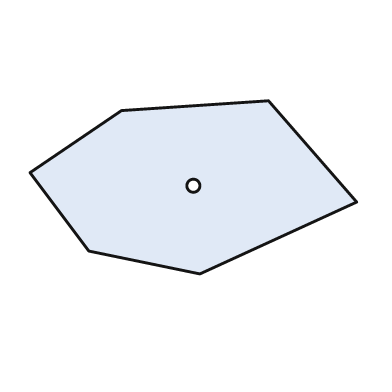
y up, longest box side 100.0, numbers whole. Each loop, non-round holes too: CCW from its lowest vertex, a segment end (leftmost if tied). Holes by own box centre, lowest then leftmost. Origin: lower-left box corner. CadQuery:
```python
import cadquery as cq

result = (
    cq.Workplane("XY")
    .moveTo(52.0, 0.0)
    .lineTo(100.0, 22.0)
    .lineTo(73.0, 53.0)
    .lineTo(28.0, 50.0)
    .lineTo(0.0, 31.0)
    .lineTo(18.0, 7.0)
    .close()
    .moveTo(50.0, 27.0)
    .circle(2.0)
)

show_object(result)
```